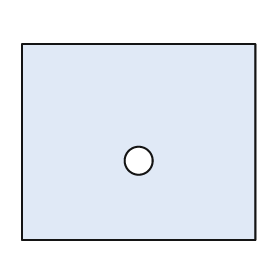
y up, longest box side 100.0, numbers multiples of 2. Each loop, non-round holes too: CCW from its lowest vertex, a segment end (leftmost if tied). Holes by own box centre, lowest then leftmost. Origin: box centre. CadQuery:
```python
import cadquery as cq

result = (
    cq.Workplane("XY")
    .moveTo(-50.0, -42.0)
    .lineTo(50.0, -42.0)
    .lineTo(50.0, 42.0)
    .lineTo(-50.0, 42.0)
    .close()
    .moveTo(0.0, -8.0)
    .circle(6.0)
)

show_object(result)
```